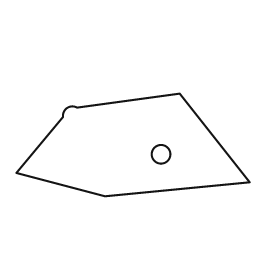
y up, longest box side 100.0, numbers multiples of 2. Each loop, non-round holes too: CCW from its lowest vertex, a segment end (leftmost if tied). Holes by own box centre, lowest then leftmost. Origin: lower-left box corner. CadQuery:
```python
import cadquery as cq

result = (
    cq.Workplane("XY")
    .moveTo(38.0, 0.0)
    .lineTo(100.0, 6.0)
    .lineTo(70.0, 44.0)
    .lineTo(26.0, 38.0)
    .threePointArc((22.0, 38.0), (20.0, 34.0))
    .lineTo(0.0, 10.0)
    .close()
    .moveTo(62.0, 18.0)
    .circle(4.0)
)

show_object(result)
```